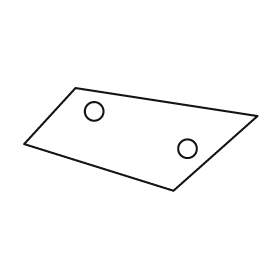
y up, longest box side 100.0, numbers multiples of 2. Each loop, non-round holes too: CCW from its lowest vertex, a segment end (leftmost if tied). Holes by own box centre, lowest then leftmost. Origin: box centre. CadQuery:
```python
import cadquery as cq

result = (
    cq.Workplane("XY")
    .moveTo(14.0, -22.0)
    .lineTo(50.0, 10.0)
    .lineTo(-28.0, 22.0)
    .lineTo(-50.0, -2.0)
    .close()
    .moveTo(20.0, -4.0)
    .circle(4.0)
    .moveTo(-20.0, 12.0)
    .circle(4.0)
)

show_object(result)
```